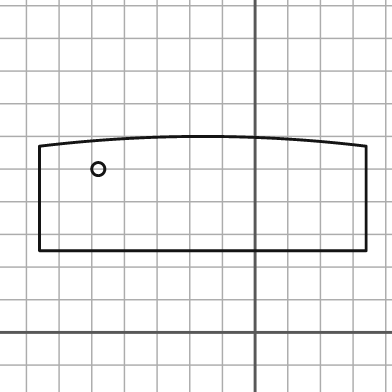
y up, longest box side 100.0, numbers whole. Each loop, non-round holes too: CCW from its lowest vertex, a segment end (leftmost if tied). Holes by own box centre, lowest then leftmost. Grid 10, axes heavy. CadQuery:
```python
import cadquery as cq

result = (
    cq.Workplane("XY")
    .moveTo(-66.0, 25.0)
    .lineTo(34.0, 25.0)
    .lineTo(34.0, 57.0)
    .threePointArc((-16.0, 60.0), (-66.0, 57.0))
    .close()
    .moveTo(-48.0, 50.0)
    .circle(2.0)
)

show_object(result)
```